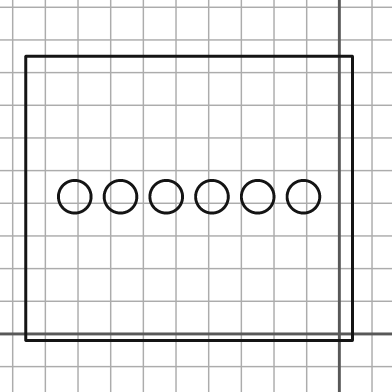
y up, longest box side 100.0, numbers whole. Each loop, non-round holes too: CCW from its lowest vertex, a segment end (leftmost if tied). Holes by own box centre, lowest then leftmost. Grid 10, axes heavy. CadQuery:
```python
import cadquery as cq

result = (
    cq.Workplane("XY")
    .moveTo(-96.0, -2.0)
    .lineTo(4.0, -2.0)
    .lineTo(4.0, 85.0)
    .lineTo(-96.0, 85.0)
    .close()
    .moveTo(-81.0, 42.0)
    .circle(5.0)
    .moveTo(-67.0, 42.0)
    .circle(5.0)
    .moveTo(-53.0, 42.0)
    .circle(5.0)
    .moveTo(-39.0, 42.0)
    .circle(5.0)
    .moveTo(-25.0, 42.0)
    .circle(5.0)
    .moveTo(-11.0, 42.0)
    .circle(5.0)
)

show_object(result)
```